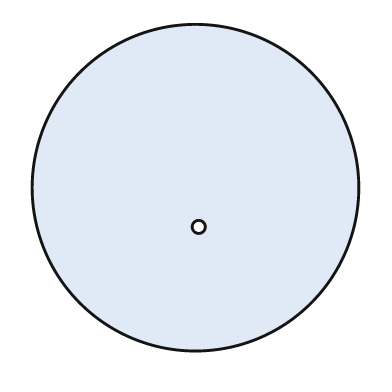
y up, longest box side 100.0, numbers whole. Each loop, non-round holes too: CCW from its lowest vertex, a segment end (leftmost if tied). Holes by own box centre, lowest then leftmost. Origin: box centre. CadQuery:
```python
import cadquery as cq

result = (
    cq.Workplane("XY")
    .moveTo(0.0, 0.0)
    .circle(50.0)
    .moveTo(1.0, -12.0)
    .circle(2.0)
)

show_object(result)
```